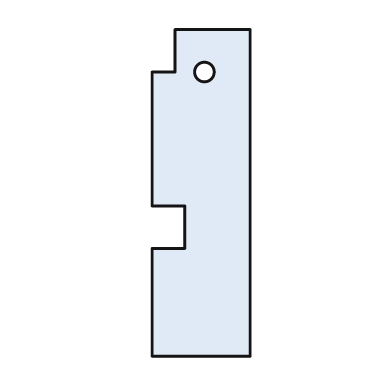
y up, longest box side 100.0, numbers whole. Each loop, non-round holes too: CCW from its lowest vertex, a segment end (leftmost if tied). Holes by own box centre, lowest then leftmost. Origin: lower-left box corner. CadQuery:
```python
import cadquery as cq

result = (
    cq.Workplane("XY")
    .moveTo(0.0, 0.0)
    .lineTo(30.0, 0.0)
    .lineTo(30.0, 100.0)
    .lineTo(7.0, 100.0)
    .lineTo(7.0, 87.0)
    .lineTo(0.0, 87.0)
    .lineTo(0.0, 46.0)
    .lineTo(10.0, 46.0)
    .lineTo(10.0, 33.0)
    .lineTo(0.0, 33.0)
    .close()
    .moveTo(16.0, 87.0)
    .circle(3.0)
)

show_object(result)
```